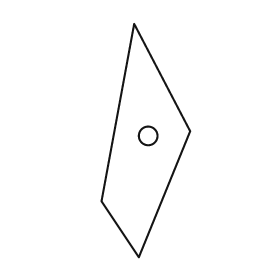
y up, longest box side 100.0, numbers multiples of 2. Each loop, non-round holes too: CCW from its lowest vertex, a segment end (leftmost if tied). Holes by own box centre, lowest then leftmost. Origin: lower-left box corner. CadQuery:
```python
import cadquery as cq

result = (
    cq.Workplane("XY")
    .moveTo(16.0, 0.0)
    .lineTo(38.0, 54.0)
    .lineTo(14.0, 100.0)
    .lineTo(0.0, 24.0)
    .close()
    .moveTo(20.0, 52.0)
    .circle(4.0)
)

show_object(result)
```